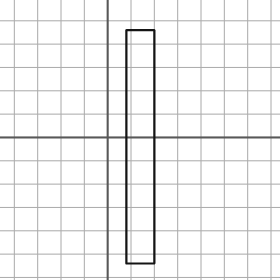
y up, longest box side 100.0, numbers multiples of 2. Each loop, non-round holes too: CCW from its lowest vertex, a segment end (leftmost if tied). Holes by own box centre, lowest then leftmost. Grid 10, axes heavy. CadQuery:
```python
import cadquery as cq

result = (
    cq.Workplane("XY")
    .moveTo(8.0, -54.0)
    .lineTo(20.0, -54.0)
    .lineTo(20.0, 46.0)
    .lineTo(8.0, 46.0)
    .close()
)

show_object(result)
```